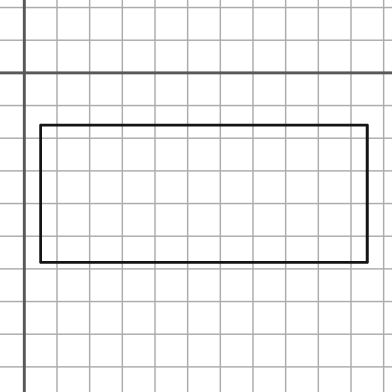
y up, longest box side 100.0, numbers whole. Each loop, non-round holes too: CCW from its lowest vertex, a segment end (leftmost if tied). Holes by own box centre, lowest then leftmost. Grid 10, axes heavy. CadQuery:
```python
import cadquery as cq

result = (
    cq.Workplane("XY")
    .moveTo(5.0, -58.0)
    .lineTo(105.0, -58.0)
    .lineTo(105.0, -16.0)
    .lineTo(5.0, -16.0)
    .close()
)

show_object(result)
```